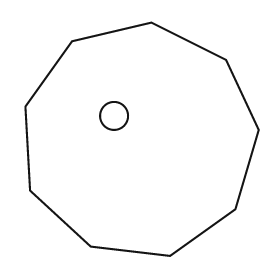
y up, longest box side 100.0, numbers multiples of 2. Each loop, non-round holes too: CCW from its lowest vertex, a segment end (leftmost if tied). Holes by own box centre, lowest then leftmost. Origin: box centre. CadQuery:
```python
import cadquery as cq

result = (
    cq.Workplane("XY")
    .moveTo(12.0, -50.0)
    .lineTo(40.0, -30.0)
    .lineTo(50.0, 4.0)
    .lineTo(36.0, 34.0)
    .lineTo(4.0, 50.0)
    .lineTo(-30.0, 42.0)
    .lineTo(-50.0, 14.0)
    .lineTo(-48.0, -22.0)
    .lineTo(-22.0, -46.0)
    .close()
    .moveTo(-12.0, 10.0)
    .circle(6.0)
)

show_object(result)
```